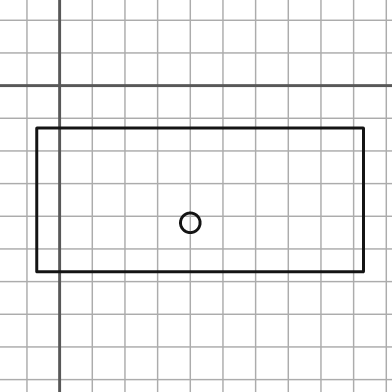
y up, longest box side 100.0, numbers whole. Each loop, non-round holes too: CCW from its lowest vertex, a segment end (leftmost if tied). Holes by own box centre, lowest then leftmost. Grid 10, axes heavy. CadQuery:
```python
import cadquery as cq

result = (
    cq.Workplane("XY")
    .moveTo(-7.0, -57.0)
    .lineTo(93.0, -57.0)
    .lineTo(93.0, -13.0)
    .lineTo(-7.0, -13.0)
    .close()
    .moveTo(40.0, -42.0)
    .circle(3.0)
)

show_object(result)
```